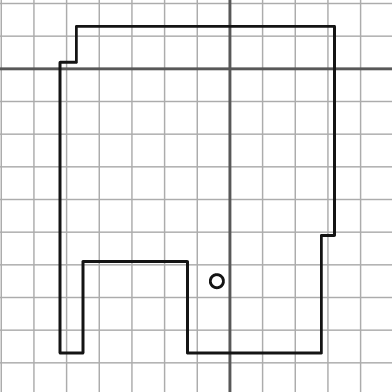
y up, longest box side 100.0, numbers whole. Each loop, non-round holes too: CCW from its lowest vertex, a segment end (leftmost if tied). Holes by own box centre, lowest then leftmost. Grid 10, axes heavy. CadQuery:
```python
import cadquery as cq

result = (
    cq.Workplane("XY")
    .moveTo(-52.0, -87.0)
    .lineTo(-45.0, -87.0)
    .lineTo(-45.0, -59.0)
    .lineTo(-13.0, -59.0)
    .lineTo(-13.0, -87.0)
    .lineTo(28.0, -87.0)
    .lineTo(28.0, -51.0)
    .lineTo(32.0, -51.0)
    .lineTo(32.0, 13.0)
    .lineTo(-47.0, 13.0)
    .lineTo(-47.0, 2.0)
    .lineTo(-52.0, 2.0)
    .close()
    .moveTo(-4.0, -65.0)
    .circle(2.0)
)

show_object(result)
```